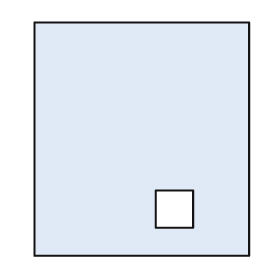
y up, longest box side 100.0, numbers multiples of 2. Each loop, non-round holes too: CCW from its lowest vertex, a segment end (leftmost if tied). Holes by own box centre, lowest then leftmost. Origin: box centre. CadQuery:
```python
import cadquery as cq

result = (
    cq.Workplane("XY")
    .moveTo(-46.0, -50.0)
    .lineTo(46.0, -50.0)
    .lineTo(46.0, 50.0)
    .lineTo(-46.0, 50.0)
    .close()
    .moveTo(6.0, -38.0)
    .lineTo(22.0, -38.0)
    .lineTo(22.0, -22.0)
    .lineTo(6.0, -22.0)
    .close()
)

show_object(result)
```